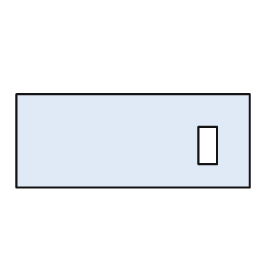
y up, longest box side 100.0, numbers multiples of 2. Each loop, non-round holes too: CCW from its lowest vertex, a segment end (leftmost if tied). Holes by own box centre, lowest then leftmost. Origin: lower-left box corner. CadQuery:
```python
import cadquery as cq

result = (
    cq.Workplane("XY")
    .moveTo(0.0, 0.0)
    .lineTo(100.0, 0.0)
    .lineTo(100.0, 40.0)
    .lineTo(0.0, 40.0)
    .close()
    .moveTo(78.0, 10.0)
    .lineTo(86.0, 10.0)
    .lineTo(86.0, 26.0)
    .lineTo(78.0, 26.0)
    .close()
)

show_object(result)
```